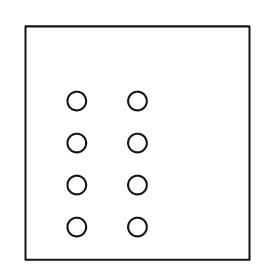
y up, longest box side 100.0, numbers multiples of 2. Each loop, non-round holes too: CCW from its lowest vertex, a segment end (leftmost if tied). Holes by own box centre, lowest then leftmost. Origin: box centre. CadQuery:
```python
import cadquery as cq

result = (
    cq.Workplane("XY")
    .moveTo(-48.0, -50.0)
    .lineTo(48.0, -50.0)
    .lineTo(48.0, 50.0)
    .lineTo(-48.0, 50.0)
    .close()
    .moveTo(-26.0, -36.0)
    .circle(4.0)
    .moveTo(0.0, -36.0)
    .circle(4.0)
    .moveTo(-26.0, -18.0)
    .circle(4.0)
    .moveTo(0.0, -18.0)
    .circle(4.0)
    .moveTo(-26.0, 0.0)
    .circle(4.0)
    .moveTo(0.0, 0.0)
    .circle(4.0)
    .moveTo(-26.0, 18.0)
    .circle(4.0)
    .moveTo(0.0, 18.0)
    .circle(4.0)
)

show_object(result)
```